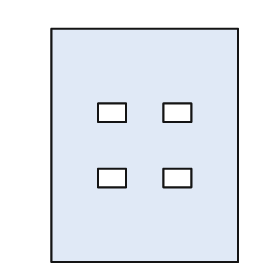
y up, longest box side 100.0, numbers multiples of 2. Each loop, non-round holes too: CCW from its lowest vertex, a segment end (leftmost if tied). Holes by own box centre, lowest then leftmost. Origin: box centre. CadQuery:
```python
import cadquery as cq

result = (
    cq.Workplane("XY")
    .moveTo(-40.0, -50.0)
    .lineTo(40.0, -50.0)
    .lineTo(40.0, 50.0)
    .lineTo(-40.0, 50.0)
    .close()
    .moveTo(-20.0, -18.0)
    .lineTo(-8.0, -18.0)
    .lineTo(-8.0, -10.0)
    .lineTo(-20.0, -10.0)
    .close()
    .moveTo(8.0, -18.0)
    .lineTo(20.0, -18.0)
    .lineTo(20.0, -10.0)
    .lineTo(8.0, -10.0)
    .close()
    .moveTo(-20.0, 10.0)
    .lineTo(-8.0, 10.0)
    .lineTo(-8.0, 18.0)
    .lineTo(-20.0, 18.0)
    .close()
    .moveTo(8.0, 10.0)
    .lineTo(20.0, 10.0)
    .lineTo(20.0, 18.0)
    .lineTo(8.0, 18.0)
    .close()
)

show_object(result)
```